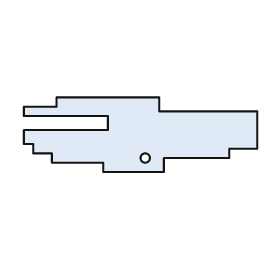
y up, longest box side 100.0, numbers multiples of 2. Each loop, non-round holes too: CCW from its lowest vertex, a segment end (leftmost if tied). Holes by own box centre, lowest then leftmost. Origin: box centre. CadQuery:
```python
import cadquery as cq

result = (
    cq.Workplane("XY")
    .moveTo(-16.0, -16.0)
    .lineTo(10.0, -16.0)
    .lineTo(10.0, -10.0)
    .lineTo(38.0, -10.0)
    .lineTo(38.0, -6.0)
    .lineTo(50.0, -6.0)
    .lineTo(50.0, 10.0)
    .lineTo(8.0, 10.0)
    .lineTo(8.0, 16.0)
    .lineTo(-36.0, 16.0)
    .lineTo(-36.0, 12.0)
    .lineTo(-50.0, 12.0)
    .lineTo(-50.0, 8.0)
    .lineTo(-14.0, 8.0)
    .lineTo(-14.0, 2.0)
    .lineTo(-50.0, 2.0)
    .lineTo(-50.0, -4.0)
    .lineTo(-46.0, -4.0)
    .lineTo(-46.0, -8.0)
    .lineTo(-38.0, -8.0)
    .lineTo(-38.0, -12.0)
    .lineTo(-16.0, -12.0)
    .close()
    .moveTo(2.0, -10.0)
    .circle(2.0)
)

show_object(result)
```